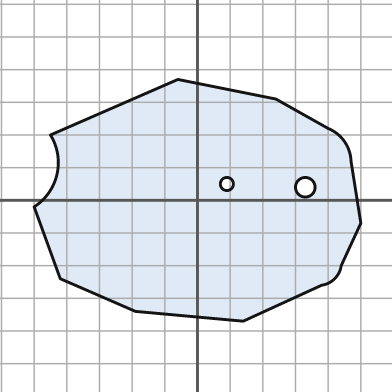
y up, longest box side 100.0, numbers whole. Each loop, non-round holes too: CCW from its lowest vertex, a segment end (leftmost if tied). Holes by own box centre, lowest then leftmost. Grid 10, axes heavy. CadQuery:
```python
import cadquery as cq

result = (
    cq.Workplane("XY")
    .moveTo(14.0, -37.0)
    .lineTo(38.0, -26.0)
    .threePointArc((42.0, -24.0), (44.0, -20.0))
    .lineTo(50.0, -7.0)
    .lineTo(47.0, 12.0)
    .threePointArc((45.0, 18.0), (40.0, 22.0))
    .lineTo(24.0, 31.0)
    .lineTo(-6.0, 37.0)
    .lineTo(-45.0, 20.0)
    .threePointArc((-43.0, 8.0), (-50.0, -2.0))
    .lineTo(-42.0, -24.0)
    .lineTo(-19.0, -34.0)
    .close()
    .moveTo(33.0, 4.0)
    .circle(3.0)
    .moveTo(9.0, 5.0)
    .circle(2.0)
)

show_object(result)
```